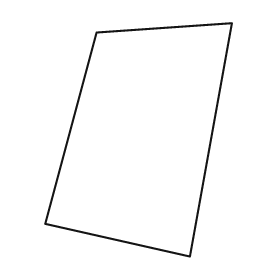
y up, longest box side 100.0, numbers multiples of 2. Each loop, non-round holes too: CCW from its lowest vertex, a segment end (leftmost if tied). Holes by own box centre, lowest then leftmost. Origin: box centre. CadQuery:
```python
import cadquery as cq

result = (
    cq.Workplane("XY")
    .moveTo(22.0, -50.0)
    .lineTo(40.0, 50.0)
    .lineTo(-18.0, 46.0)
    .lineTo(-40.0, -36.0)
    .close()
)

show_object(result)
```